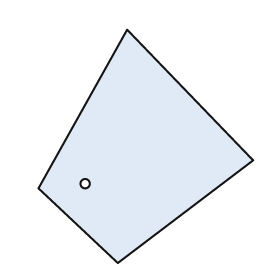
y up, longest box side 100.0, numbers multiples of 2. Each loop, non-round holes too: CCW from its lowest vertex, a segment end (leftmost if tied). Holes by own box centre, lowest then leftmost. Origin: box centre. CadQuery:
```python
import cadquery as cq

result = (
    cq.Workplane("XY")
    .moveTo(-12.0, -50.0)
    .lineTo(46.0, -6.0)
    .lineTo(-8.0, 50.0)
    .lineTo(-46.0, -18.0)
    .close()
    .moveTo(-26.0, -16.0)
    .circle(2.0)
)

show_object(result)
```